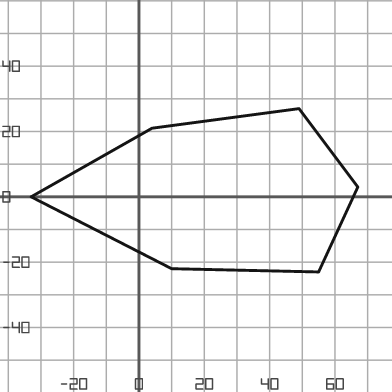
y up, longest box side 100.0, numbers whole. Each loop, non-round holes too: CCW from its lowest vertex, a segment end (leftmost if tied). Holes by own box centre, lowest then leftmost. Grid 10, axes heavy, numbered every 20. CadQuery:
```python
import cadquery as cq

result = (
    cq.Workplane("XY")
    .moveTo(55.0, -23.0)
    .lineTo(67.0, 3.0)
    .lineTo(49.0, 27.0)
    .lineTo(4.0, 21.0)
    .lineTo(-33.0, 0.0)
    .lineTo(10.0, -22.0)
    .close()
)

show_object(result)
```